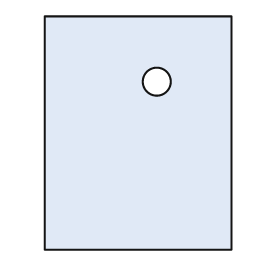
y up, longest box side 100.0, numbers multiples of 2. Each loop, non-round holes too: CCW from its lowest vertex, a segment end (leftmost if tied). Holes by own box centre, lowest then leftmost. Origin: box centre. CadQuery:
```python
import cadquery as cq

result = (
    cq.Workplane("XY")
    .moveTo(-40.0, -50.0)
    .lineTo(40.0, -50.0)
    .lineTo(40.0, 50.0)
    .lineTo(-40.0, 50.0)
    .close()
    .moveTo(8.0, 22.0)
    .circle(6.0)
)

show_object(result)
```